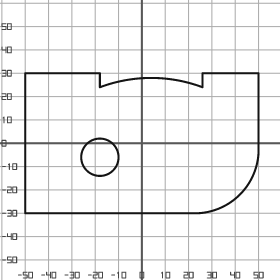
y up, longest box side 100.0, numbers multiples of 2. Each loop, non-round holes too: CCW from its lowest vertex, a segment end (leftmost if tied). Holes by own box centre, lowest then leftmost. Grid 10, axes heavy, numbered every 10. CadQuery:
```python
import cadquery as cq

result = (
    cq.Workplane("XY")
    .moveTo(-50.0, -30.0)
    .lineTo(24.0, -30.0)
    .threePointArc((42.0, -22.0), (50.0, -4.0))
    .lineTo(50.0, 30.0)
    .lineTo(26.0, 30.0)
    .lineTo(26.0, 24.0)
    .threePointArc((4.0, 28.0), (-18.0, 24.0))
    .lineTo(-18.0, 30.0)
    .lineTo(-50.0, 30.0)
    .close()
    .moveTo(-18.0, -6.0)
    .circle(8.0)
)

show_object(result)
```